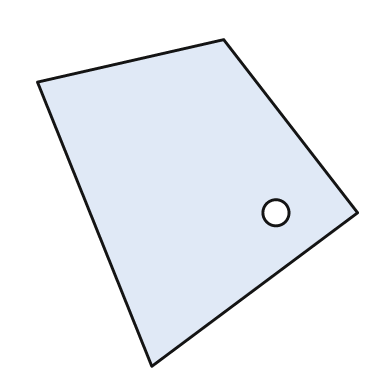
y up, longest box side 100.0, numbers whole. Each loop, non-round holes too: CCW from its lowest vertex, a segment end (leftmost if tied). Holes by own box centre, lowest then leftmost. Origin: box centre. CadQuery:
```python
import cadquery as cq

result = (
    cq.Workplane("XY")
    .moveTo(-14.0, -50.0)
    .lineTo(49.0, -3.0)
    .lineTo(8.0, 50.0)
    .lineTo(-49.0, 37.0)
    .close()
    .moveTo(24.0, -3.0)
    .circle(4.0)
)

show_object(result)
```